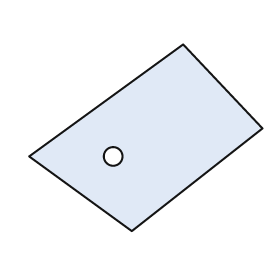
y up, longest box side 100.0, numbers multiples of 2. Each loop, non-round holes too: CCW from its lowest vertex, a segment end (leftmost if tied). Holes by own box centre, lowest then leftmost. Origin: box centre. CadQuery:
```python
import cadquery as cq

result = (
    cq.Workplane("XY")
    .moveTo(-6.0, -40.0)
    .lineTo(50.0, 4.0)
    .lineTo(16.0, 40.0)
    .lineTo(-50.0, -8.0)
    .close()
    .moveTo(-14.0, -8.0)
    .circle(4.0)
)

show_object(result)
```